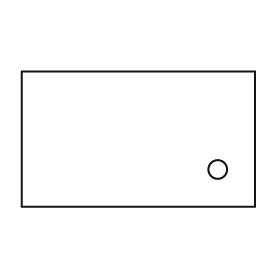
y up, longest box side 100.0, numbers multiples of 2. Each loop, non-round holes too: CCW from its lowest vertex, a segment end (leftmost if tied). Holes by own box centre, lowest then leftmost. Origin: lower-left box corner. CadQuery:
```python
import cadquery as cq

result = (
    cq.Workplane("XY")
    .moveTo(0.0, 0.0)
    .lineTo(100.0, 0.0)
    .lineTo(100.0, 58.0)
    .lineTo(0.0, 58.0)
    .close()
    .moveTo(84.0, 16.0)
    .circle(4.0)
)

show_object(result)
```